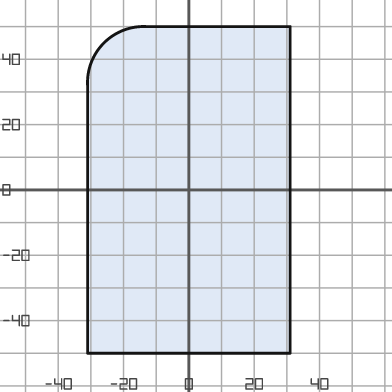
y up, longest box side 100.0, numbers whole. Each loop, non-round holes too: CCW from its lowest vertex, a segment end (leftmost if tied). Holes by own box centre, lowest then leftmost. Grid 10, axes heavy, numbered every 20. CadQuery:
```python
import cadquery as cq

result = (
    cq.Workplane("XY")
    .moveTo(-31.0, -50.0)
    .lineTo(31.0, -50.0)
    .lineTo(31.0, 50.0)
    .lineTo(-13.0, 50.0)
    .threePointArc((-26.0, 45.0), (-31.0, 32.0))
    .close()
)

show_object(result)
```